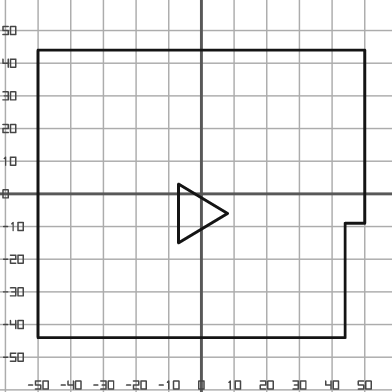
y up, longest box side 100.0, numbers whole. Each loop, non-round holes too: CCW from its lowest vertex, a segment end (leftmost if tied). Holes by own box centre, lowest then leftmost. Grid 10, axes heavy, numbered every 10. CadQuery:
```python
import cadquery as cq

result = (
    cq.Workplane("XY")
    .moveTo(-50.0, -44.0)
    .lineTo(44.0, -44.0)
    .lineTo(44.0, -9.0)
    .lineTo(50.0, -9.0)
    .lineTo(50.0, 44.0)
    .lineTo(-50.0, 44.0)
    .close()
    .moveTo(-7.0, -15.0)
    .lineTo(8.0, -6.0)
    .lineTo(-7.0, 3.0)
    .close()
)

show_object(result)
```